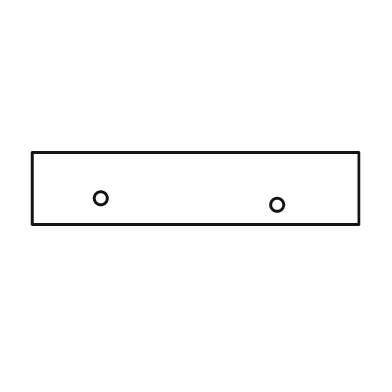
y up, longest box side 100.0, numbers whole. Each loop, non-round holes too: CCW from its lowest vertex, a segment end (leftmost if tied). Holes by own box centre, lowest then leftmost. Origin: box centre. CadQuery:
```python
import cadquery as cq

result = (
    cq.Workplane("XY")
    .moveTo(-50.0, -11.0)
    .lineTo(50.0, -11.0)
    .lineTo(50.0, 11.0)
    .lineTo(-50.0, 11.0)
    .close()
    .moveTo(25.0, -5.0)
    .circle(2.0)
    .moveTo(-29.0, -3.0)
    .circle(2.0)
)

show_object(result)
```